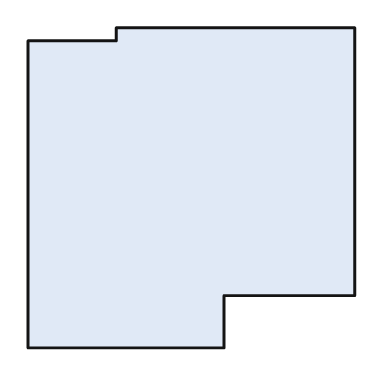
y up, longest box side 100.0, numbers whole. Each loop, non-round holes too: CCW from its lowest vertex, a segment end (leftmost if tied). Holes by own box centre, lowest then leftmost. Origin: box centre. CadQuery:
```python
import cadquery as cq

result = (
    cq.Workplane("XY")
    .moveTo(-50.0, -49.0)
    .lineTo(10.0, -49.0)
    .lineTo(10.0, -33.0)
    .lineTo(50.0, -33.0)
    .lineTo(50.0, 49.0)
    .lineTo(-23.0, 49.0)
    .lineTo(-23.0, 45.0)
    .lineTo(-50.0, 45.0)
    .close()
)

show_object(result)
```